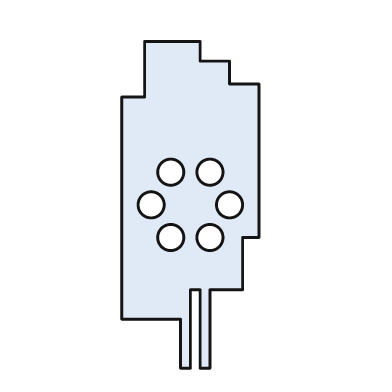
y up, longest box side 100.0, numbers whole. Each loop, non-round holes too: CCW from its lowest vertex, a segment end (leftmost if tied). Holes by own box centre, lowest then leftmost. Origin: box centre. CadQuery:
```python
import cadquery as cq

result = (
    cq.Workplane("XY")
    .moveTo(-3.0, -50.0)
    .lineTo(0.0, -50.0)
    .lineTo(0.0, -26.0)
    .lineTo(3.0, -26.0)
    .lineTo(3.0, -50.0)
    .lineTo(6.0, -50.0)
    .lineTo(6.0, -26.0)
    .lineTo(16.0, -26.0)
    .lineTo(16.0, -10.0)
    .lineTo(21.0, -10.0)
    .lineTo(21.0, 37.0)
    .lineTo(12.0, 37.0)
    .lineTo(12.0, 44.0)
    .lineTo(3.0, 44.0)
    .lineTo(3.0, 50.0)
    .lineTo(-14.0, 50.0)
    .lineTo(-14.0, 33.0)
    .lineTo(-21.0, 33.0)
    .lineTo(-21.0, -35.0)
    .lineTo(-3.0, -35.0)
    .close()
    .moveTo(-6.0, -10.0)
    .circle(4.0)
    .moveTo(6.0, -10.0)
    .circle(4.0)
    .moveTo(-12.0, 0.0)
    .circle(4.0)
    .moveTo(12.0, 0.0)
    .circle(4.0)
    .moveTo(-6.0, 10.0)
    .circle(4.0)
    .moveTo(6.0, 10.0)
    .circle(4.0)
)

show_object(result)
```